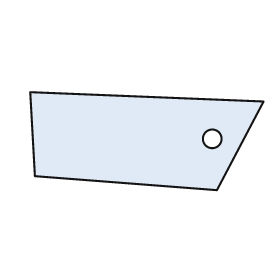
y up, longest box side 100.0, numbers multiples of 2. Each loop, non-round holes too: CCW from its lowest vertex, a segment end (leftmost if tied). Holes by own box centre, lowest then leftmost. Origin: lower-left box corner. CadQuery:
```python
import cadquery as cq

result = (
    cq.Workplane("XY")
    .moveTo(80.0, 0.0)
    .lineTo(100.0, 38.0)
    .lineTo(0.0, 42.0)
    .lineTo(2.0, 6.0)
    .close()
    .moveTo(78.0, 22.0)
    .circle(4.0)
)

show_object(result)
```